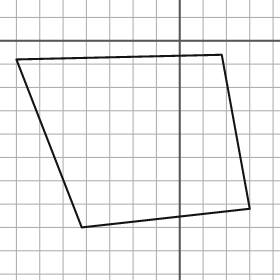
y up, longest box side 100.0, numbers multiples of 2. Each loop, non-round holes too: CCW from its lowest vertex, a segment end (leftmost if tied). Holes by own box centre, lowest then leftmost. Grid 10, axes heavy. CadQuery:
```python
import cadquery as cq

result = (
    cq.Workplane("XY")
    .moveTo(-42.0, -80.0)
    .lineTo(30.0, -72.0)
    .lineTo(18.0, -6.0)
    .lineTo(-70.0, -8.0)
    .close()
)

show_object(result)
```